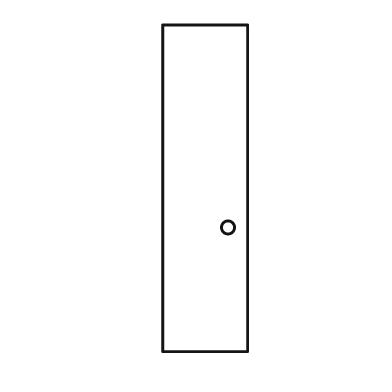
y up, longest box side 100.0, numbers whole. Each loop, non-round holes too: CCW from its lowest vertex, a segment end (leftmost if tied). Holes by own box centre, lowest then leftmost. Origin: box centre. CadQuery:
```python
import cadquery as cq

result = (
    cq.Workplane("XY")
    .moveTo(-13.0, -50.0)
    .lineTo(13.0, -50.0)
    .lineTo(13.0, 50.0)
    .lineTo(-13.0, 50.0)
    .close()
    .moveTo(7.0, -12.0)
    .circle(2.0)
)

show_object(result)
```